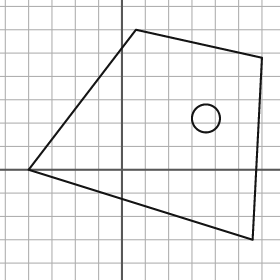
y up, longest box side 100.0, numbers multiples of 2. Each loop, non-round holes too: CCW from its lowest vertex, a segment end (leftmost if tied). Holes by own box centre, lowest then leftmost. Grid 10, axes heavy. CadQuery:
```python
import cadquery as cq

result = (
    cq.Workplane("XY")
    .moveTo(56.0, -30.0)
    .lineTo(60.0, 48.0)
    .lineTo(6.0, 60.0)
    .lineTo(-40.0, 0.0)
    .close()
    .moveTo(36.0, 22.0)
    .circle(6.0)
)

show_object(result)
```